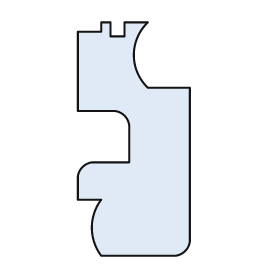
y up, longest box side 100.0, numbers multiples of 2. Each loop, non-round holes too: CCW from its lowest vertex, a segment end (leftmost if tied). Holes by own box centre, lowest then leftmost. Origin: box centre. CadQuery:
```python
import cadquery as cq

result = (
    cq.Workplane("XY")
    .moveTo(-14.0, -50.0)
    .lineTo(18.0, -50.0)
    .threePointArc((22.0, -48.0), (24.0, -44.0))
    .lineTo(24.0, 22.0)
    .lineTo(6.0, 22.0)
    .threePointArc((0.0, 36.0), (6.0, 50.0))
    .lineTo(-4.0, 50.0)
    .lineTo(-4.0, 44.0)
    .lineTo(-10.0, 44.0)
    .lineTo(-10.0, 50.0)
    .lineTo(-14.0, 50.0)
    .lineTo(-14.0, 46.0)
    .lineTo(-24.0, 46.0)
    .lineTo(-24.0, 12.0)
    .lineTo(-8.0, 12.0)
    .threePointArc((-4.0, 10.0), (-2.0, 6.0))
    .lineTo(-2.0, -10.0)
    .lineTo(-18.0, -10.0)
    .threePointArc((-22.0, -12.0), (-24.0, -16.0))
    .lineTo(-24.0, -26.0)
    .lineTo(-14.0, -26.0)
    .threePointArc((-18.0, -38.0), (-14.0, -50.0))
    .close()
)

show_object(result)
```